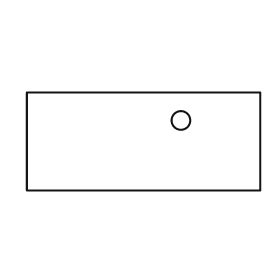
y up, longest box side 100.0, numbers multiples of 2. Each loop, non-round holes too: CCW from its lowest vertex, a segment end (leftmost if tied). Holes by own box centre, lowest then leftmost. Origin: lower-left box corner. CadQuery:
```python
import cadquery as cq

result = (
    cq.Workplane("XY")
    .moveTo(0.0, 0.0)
    .lineTo(100.0, 0.0)
    .lineTo(100.0, 42.0)
    .lineTo(0.0, 42.0)
    .close()
    .moveTo(66.0, 30.0)
    .circle(4.0)
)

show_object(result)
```